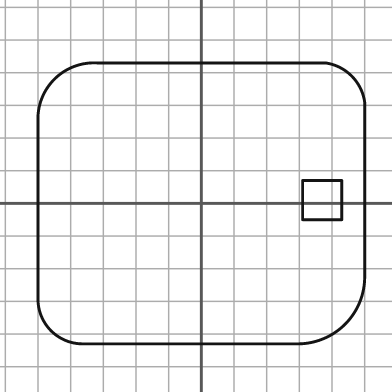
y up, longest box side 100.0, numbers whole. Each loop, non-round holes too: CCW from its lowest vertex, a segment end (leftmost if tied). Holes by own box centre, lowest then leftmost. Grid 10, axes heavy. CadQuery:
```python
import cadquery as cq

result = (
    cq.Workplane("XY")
    .moveTo(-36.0, -43.0)
    .lineTo(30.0, -43.0)
    .threePointArc((44.0, -37.0), (50.0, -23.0))
    .lineTo(50.0, 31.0)
    .threePointArc((46.0, 39.0), (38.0, 43.0))
    .lineTo(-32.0, 43.0)
    .threePointArc((-45.0, 38.0), (-50.0, 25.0))
    .lineTo(-50.0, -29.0)
    .threePointArc((-46.0, -39.0), (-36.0, -43.0))
    .close()
    .moveTo(31.0, -5.0)
    .lineTo(43.0, -5.0)
    .lineTo(43.0, 7.0)
    .lineTo(31.0, 7.0)
    .close()
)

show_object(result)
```